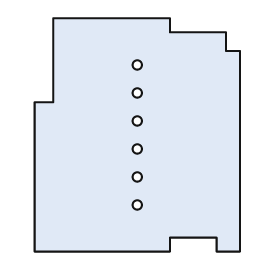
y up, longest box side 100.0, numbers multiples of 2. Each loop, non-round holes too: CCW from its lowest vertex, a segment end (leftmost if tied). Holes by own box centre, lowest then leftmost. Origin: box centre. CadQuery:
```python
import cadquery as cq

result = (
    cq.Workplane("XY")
    .moveTo(-44.0, -50.0)
    .lineTo(14.0, -50.0)
    .lineTo(14.0, -44.0)
    .lineTo(34.0, -44.0)
    .lineTo(34.0, -50.0)
    .lineTo(44.0, -50.0)
    .lineTo(44.0, 36.0)
    .lineTo(38.0, 36.0)
    .lineTo(38.0, 44.0)
    .lineTo(14.0, 44.0)
    .lineTo(14.0, 50.0)
    .lineTo(-36.0, 50.0)
    .lineTo(-36.0, 14.0)
    .lineTo(-44.0, 14.0)
    .close()
    .moveTo(0.0, -30.0)
    .circle(2.0)
    .moveTo(0.0, -18.0)
    .circle(2.0)
    .moveTo(0.0, -6.0)
    .circle(2.0)
    .moveTo(0.0, 6.0)
    .circle(2.0)
    .moveTo(0.0, 18.0)
    .circle(2.0)
    .moveTo(0.0, 30.0)
    .circle(2.0)
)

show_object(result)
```